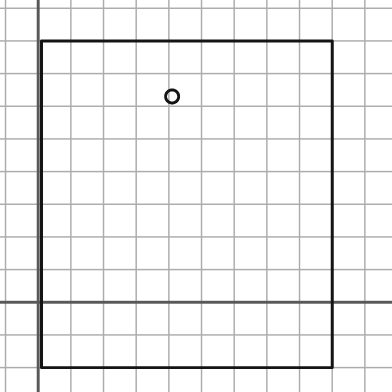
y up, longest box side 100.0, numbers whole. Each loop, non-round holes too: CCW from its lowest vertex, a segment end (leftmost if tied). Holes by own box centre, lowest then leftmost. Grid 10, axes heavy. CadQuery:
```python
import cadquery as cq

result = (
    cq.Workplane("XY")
    .moveTo(1.0, -20.0)
    .lineTo(90.0, -20.0)
    .lineTo(90.0, 80.0)
    .lineTo(1.0, 80.0)
    .close()
    .moveTo(41.0, 63.0)
    .circle(2.0)
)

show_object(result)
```